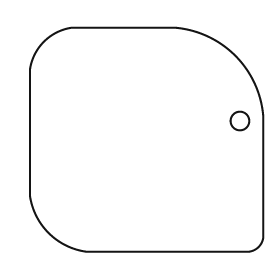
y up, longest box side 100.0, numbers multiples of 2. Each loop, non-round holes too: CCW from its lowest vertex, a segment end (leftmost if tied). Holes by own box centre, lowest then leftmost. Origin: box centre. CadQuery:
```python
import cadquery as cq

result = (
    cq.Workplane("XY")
    .moveTo(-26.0, -48.0)
    .lineTo(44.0, -48.0)
    .threePointArc((48.0, -46.0), (50.0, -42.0))
    .lineTo(50.0, 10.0)
    .threePointArc((38.0, 36.0), (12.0, 48.0))
    .lineTo(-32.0, 48.0)
    .threePointArc((-44.0, 42.0), (-50.0, 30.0))
    .lineTo(-50.0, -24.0)
    .threePointArc((-42.0, -40.0), (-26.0, -48.0))
    .close()
    .moveTo(40.0, 8.0)
    .circle(4.0)
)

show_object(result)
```